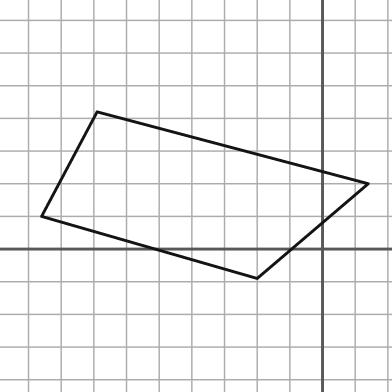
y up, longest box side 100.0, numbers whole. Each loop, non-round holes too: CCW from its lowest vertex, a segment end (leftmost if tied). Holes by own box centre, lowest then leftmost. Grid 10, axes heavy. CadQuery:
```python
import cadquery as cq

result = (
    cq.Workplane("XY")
    .moveTo(-20.0, -9.0)
    .lineTo(14.0, 20.0)
    .lineTo(-69.0, 42.0)
    .lineTo(-86.0, 10.0)
    .close()
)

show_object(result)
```